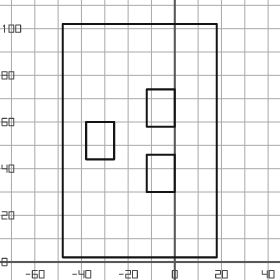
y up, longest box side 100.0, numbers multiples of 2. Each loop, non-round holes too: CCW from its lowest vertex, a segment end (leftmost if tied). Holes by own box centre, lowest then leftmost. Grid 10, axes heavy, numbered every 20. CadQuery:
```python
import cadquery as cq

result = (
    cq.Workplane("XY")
    .moveTo(-48.0, 2.0)
    .lineTo(18.0, 2.0)
    .lineTo(18.0, 102.0)
    .lineTo(-48.0, 102.0)
    .close()
    .moveTo(-12.0, 30.0)
    .lineTo(0.0, 30.0)
    .lineTo(0.0, 46.0)
    .lineTo(-12.0, 46.0)
    .close()
    .moveTo(-38.0, 44.0)
    .lineTo(-26.0, 44.0)
    .lineTo(-26.0, 60.0)
    .lineTo(-38.0, 60.0)
    .close()
    .moveTo(-12.0, 58.0)
    .lineTo(0.0, 58.0)
    .lineTo(0.0, 74.0)
    .lineTo(-12.0, 74.0)
    .close()
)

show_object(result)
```